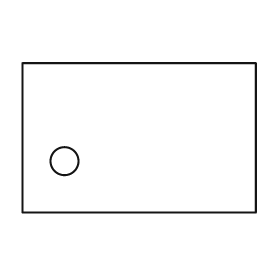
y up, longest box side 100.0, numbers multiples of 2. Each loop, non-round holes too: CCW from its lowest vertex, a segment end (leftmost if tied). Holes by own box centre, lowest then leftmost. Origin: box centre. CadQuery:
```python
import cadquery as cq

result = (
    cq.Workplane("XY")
    .moveTo(-50.0, -32.0)
    .lineTo(50.0, -32.0)
    .lineTo(50.0, 32.0)
    .lineTo(-50.0, 32.0)
    .close()
    .moveTo(-32.0, -10.0)
    .circle(6.0)
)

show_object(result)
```